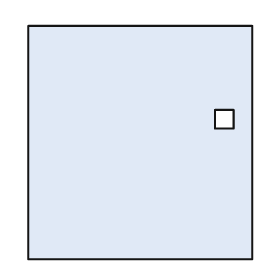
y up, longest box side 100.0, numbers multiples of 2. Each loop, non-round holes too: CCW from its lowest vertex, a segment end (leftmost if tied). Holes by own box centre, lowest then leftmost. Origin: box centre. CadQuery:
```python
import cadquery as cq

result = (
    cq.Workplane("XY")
    .moveTo(-48.0, -50.0)
    .lineTo(48.0, -50.0)
    .lineTo(48.0, 50.0)
    .lineTo(-48.0, 50.0)
    .close()
    .moveTo(32.0, 6.0)
    .lineTo(40.0, 6.0)
    .lineTo(40.0, 14.0)
    .lineTo(32.0, 14.0)
    .close()
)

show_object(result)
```